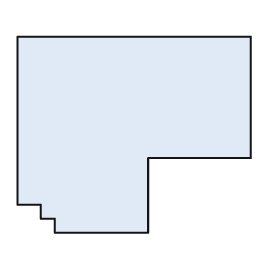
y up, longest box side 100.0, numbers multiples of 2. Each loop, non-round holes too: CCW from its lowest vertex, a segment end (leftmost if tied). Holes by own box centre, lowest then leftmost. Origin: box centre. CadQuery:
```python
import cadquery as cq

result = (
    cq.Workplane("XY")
    .moveTo(-34.0, -42.0)
    .lineTo(6.0, -42.0)
    .lineTo(6.0, -10.0)
    .lineTo(50.0, -10.0)
    .lineTo(50.0, 42.0)
    .lineTo(-50.0, 42.0)
    .lineTo(-50.0, -30.0)
    .lineTo(-40.0, -30.0)
    .lineTo(-40.0, -36.0)
    .lineTo(-34.0, -36.0)
    .close()
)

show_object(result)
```